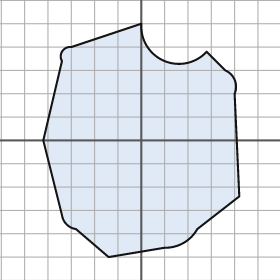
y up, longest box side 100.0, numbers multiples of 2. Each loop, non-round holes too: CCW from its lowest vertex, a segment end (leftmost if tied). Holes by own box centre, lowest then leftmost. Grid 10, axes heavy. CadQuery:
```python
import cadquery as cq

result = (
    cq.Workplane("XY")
    .moveTo(-14.0, -50.0)
    .lineTo(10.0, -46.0)
    .threePointArc((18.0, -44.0), (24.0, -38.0))
    .lineTo(42.0, -24.0)
    .lineTo(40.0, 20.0)
    .threePointArc((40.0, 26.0), (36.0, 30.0))
    .lineTo(28.0, 38.0)
    .threePointArc((10.0, 34.0), (0.0, 50.0))
    .lineTo(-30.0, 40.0)
    .threePointArc((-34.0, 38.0), (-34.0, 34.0))
    .lineTo(-42.0, 0.0)
    .lineTo(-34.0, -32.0)
    .threePointArc((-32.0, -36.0), (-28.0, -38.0))
    .close()
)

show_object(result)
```